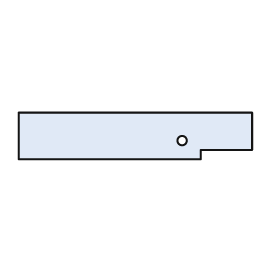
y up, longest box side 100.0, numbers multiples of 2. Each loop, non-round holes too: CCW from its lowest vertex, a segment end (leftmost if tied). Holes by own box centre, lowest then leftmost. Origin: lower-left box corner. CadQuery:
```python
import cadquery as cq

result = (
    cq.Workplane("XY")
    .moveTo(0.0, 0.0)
    .lineTo(78.0, 0.0)
    .lineTo(78.0, 4.0)
    .lineTo(100.0, 4.0)
    .lineTo(100.0, 20.0)
    .lineTo(0.0, 20.0)
    .close()
    .moveTo(70.0, 8.0)
    .circle(2.0)
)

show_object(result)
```